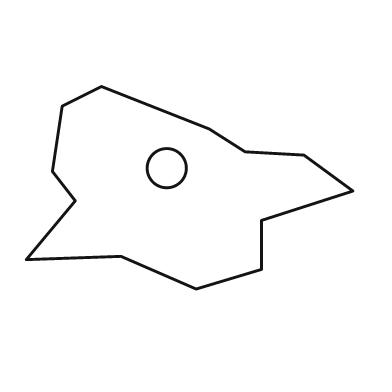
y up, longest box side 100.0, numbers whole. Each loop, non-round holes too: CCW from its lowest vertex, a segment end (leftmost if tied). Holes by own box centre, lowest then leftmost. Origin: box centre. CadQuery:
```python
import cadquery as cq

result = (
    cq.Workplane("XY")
    .moveTo(2.0, -31.0)
    .lineTo(22.0, -25.0)
    .lineTo(22.0, -10.0)
    .lineTo(50.0, -1.0)
    .lineTo(35.0, 10.0)
    .lineTo(17.0, 11.0)
    .lineTo(6.0, 18.0)
    .lineTo(-27.0, 31.0)
    .lineTo(-39.0, 25.0)
    .lineTo(-42.0, 5.0)
    .lineTo(-35.0, -4.0)
    .lineTo(-50.0, -22.0)
    .lineTo(-21.0, -21.0)
    .close()
    .moveTo(-7.0, 6.0)
    .circle(6.0)
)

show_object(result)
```